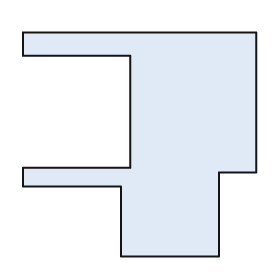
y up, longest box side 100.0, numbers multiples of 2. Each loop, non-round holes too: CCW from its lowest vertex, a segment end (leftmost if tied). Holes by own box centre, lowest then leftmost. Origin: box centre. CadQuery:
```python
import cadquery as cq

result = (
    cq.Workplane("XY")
    .moveTo(-8.0, -48.0)
    .lineTo(34.0, -48.0)
    .lineTo(34.0, -12.0)
    .lineTo(50.0, -12.0)
    .lineTo(50.0, 48.0)
    .lineTo(-50.0, 48.0)
    .lineTo(-50.0, 38.0)
    .lineTo(-4.0, 38.0)
    .lineTo(-4.0, -10.0)
    .lineTo(-50.0, -10.0)
    .lineTo(-50.0, -18.0)
    .lineTo(-8.0, -18.0)
    .close()
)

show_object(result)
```